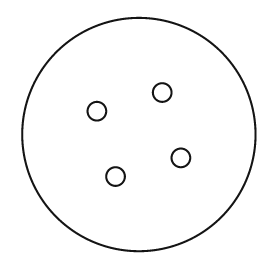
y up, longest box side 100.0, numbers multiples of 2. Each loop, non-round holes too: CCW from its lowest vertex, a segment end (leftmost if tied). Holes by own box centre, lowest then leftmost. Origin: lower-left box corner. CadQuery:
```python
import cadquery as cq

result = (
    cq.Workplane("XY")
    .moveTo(50.0, 50.0)
    .circle(50.0)
    .moveTo(40.0, 32.0)
    .circle(4.0)
    .moveTo(68.0, 40.0)
    .circle(4.0)
    .moveTo(32.0, 60.0)
    .circle(4.0)
    .moveTo(60.0, 68.0)
    .circle(4.0)
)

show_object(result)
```